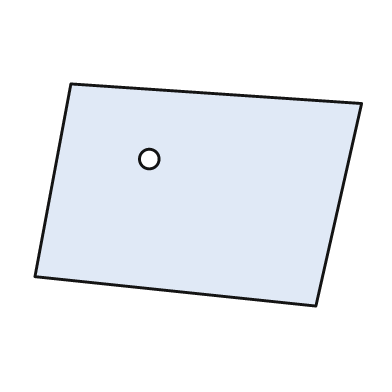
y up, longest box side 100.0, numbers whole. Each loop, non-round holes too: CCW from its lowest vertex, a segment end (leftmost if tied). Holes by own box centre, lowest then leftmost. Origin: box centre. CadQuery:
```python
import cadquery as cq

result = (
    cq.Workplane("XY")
    .moveTo(36.0, -34.0)
    .lineTo(50.0, 28.0)
    .lineTo(-39.0, 34.0)
    .lineTo(-50.0, -25.0)
    .close()
    .moveTo(-15.0, 11.0)
    .circle(3.0)
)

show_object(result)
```